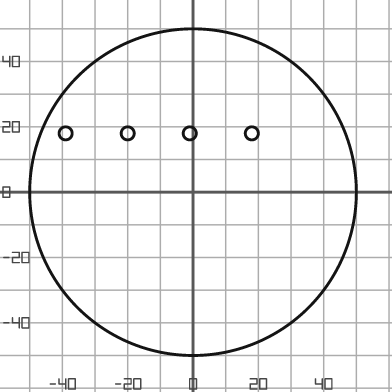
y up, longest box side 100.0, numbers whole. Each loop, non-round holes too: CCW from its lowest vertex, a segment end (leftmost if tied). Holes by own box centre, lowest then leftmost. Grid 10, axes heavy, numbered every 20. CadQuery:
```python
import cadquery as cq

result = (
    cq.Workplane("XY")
    .moveTo(0.0, 0.0)
    .circle(50.0)
    .moveTo(-39.0, 18.0)
    .circle(2.0)
    .moveTo(-20.0, 18.0)
    .circle(2.0)
    .moveTo(-1.0, 18.0)
    .circle(2.0)
    .moveTo(18.0, 18.0)
    .circle(2.0)
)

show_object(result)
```